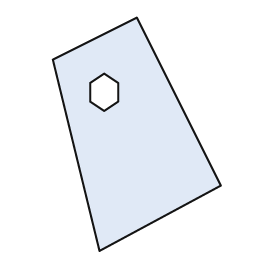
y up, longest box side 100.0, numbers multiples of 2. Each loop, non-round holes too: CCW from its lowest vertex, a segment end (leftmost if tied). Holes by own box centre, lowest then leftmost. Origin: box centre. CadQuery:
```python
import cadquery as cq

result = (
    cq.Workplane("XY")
    .moveTo(-16.0, -50.0)
    .lineTo(36.0, -22.0)
    .lineTo(0.0, 50.0)
    .lineTo(-36.0, 32.0)
    .close()
    .moveTo(-14.0, 10.0)
    .lineTo(-8.0, 14.0)
    .lineTo(-8.0, 22.0)
    .lineTo(-14.0, 26.0)
    .lineTo(-20.0, 22.0)
    .lineTo(-20.0, 14.0)
    .close()
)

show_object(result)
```